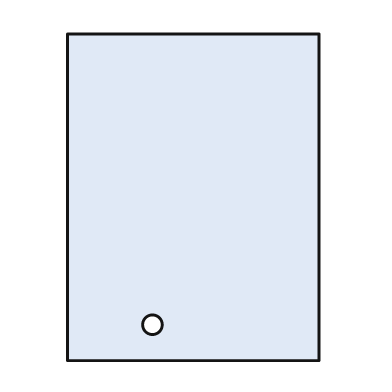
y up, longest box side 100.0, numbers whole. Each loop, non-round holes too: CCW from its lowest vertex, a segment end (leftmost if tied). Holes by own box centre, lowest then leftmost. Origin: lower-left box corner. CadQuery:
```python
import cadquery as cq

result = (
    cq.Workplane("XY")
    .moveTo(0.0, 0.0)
    .lineTo(77.0, 0.0)
    .lineTo(77.0, 100.0)
    .lineTo(0.0, 100.0)
    .close()
    .moveTo(26.0, 11.0)
    .circle(3.0)
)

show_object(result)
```